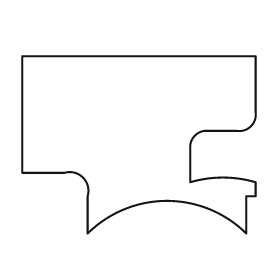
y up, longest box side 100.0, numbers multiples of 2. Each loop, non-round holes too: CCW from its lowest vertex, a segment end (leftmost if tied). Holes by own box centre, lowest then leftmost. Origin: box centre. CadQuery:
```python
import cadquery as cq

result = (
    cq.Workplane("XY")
    .moveTo(-22.0, -38.0)
    .threePointArc((12.0, -24.0), (46.0, -38.0))
    .lineTo(46.0, -22.0)
    .lineTo(50.0, -22.0)
    .lineTo(50.0, -16.0)
    .threePointArc((36.0, -14.0), (22.0, -16.0))
    .lineTo(22.0, 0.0)
    .threePointArc((24.0, 4.0), (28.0, 6.0))
    .lineTo(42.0, 6.0)
    .threePointArc((48.0, 8.0), (50.0, 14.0))
    .lineTo(50.0, 38.0)
    .lineTo(-50.0, 38.0)
    .lineTo(-50.0, -12.0)
    .lineTo(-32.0, -12.0)
    .threePointArc((-24.0, -14.0), (-22.0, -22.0))
    .close()
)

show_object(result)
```